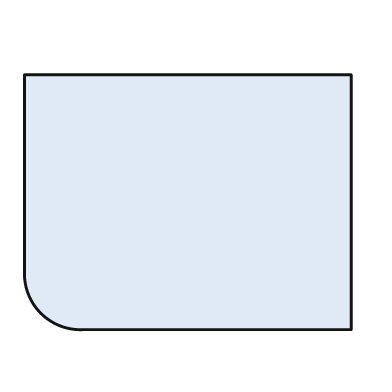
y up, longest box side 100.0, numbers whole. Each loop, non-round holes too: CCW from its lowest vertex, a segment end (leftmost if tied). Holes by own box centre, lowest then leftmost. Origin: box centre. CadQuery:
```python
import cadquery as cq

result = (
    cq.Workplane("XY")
    .moveTo(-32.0, -39.0)
    .lineTo(50.0, -39.0)
    .lineTo(50.0, 39.0)
    .lineTo(-50.0, 39.0)
    .lineTo(-50.0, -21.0)
    .threePointArc((-45.0, -34.0), (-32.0, -39.0))
    .close()
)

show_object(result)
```